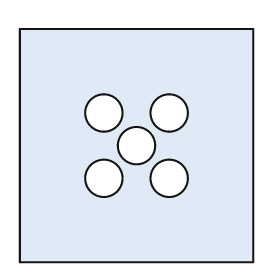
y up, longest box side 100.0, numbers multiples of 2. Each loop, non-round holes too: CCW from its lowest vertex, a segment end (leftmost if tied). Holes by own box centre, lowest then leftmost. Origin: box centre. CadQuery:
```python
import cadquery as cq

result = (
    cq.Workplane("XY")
    .moveTo(-50.0, -50.0)
    .lineTo(50.0, -50.0)
    .lineTo(50.0, 50.0)
    .lineTo(-50.0, 50.0)
    .close()
    .moveTo(-14.0, -14.0)
    .circle(8.0)
    .moveTo(14.0, -14.0)
    .circle(8.0)
    .moveTo(0.0, 0.0)
    .circle(8.0)
    .moveTo(-14.0, 14.0)
    .circle(8.0)
    .moveTo(14.0, 14.0)
    .circle(8.0)
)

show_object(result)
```